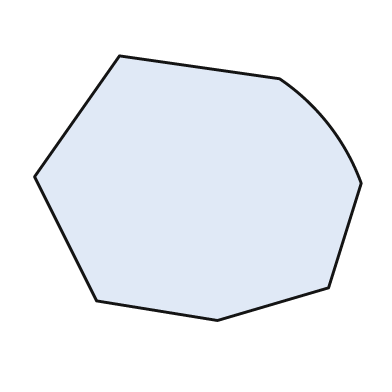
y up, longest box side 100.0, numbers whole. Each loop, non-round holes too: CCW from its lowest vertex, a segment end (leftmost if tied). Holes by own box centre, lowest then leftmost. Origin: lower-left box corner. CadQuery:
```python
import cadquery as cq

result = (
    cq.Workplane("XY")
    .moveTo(56.0, 0.0)
    .lineTo(90.0, 10.0)
    .lineTo(100.0, 42.0)
    .threePointArc((90.0, 60.0), (75.0, 74.0))
    .lineTo(26.0, 81.0)
    .lineTo(0.0, 44.0)
    .lineTo(19.0, 6.0)
    .close()
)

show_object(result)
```